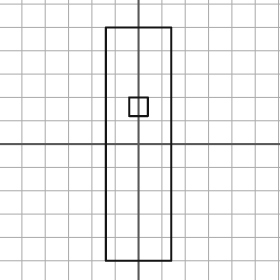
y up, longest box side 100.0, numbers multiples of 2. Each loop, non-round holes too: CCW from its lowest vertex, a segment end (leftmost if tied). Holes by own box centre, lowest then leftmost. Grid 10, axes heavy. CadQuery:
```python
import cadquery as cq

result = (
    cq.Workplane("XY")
    .moveTo(-14.0, -50.0)
    .lineTo(14.0, -50.0)
    .lineTo(14.0, 50.0)
    .lineTo(-14.0, 50.0)
    .close()
    .moveTo(-4.0, 12.0)
    .lineTo(4.0, 12.0)
    .lineTo(4.0, 20.0)
    .lineTo(-4.0, 20.0)
    .close()
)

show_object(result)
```